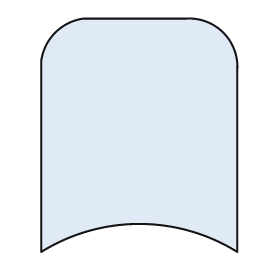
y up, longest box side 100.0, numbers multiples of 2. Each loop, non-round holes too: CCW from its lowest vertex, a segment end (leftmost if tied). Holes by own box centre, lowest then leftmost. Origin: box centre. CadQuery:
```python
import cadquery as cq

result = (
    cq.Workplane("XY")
    .moveTo(-42.0, -50.0)
    .threePointArc((0.0, -38.0), (42.0, -50.0))
    .lineTo(42.0, 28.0)
    .threePointArc((36.0, 44.0), (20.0, 50.0))
    .lineTo(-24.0, 50.0)
    .threePointArc((-36.0, 44.0), (-42.0, 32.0))
    .close()
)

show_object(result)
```